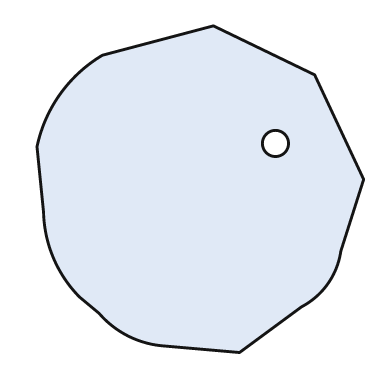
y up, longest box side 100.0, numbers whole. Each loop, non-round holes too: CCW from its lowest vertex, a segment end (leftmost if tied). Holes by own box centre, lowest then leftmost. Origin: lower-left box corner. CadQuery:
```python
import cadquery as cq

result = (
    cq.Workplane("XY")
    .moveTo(62.0, 0.0)
    .lineTo(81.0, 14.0)
    .threePointArc((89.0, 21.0), (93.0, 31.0))
    .lineTo(100.0, 53.0)
    .lineTo(85.0, 85.0)
    .lineTo(54.0, 100.0)
    .lineTo(20.0, 91.0)
    .threePointArc((7.0, 79.0), (0.0, 63.0))
    .lineTo(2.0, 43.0)
    .threePointArc((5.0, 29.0), (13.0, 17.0))
    .lineTo(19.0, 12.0)
    .threePointArc((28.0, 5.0), (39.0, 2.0))
    .close()
    .moveTo(73.0, 64.0)
    .circle(4.0)
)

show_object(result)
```